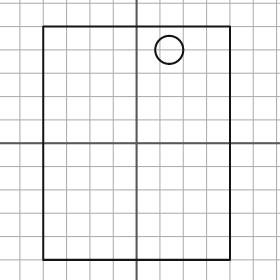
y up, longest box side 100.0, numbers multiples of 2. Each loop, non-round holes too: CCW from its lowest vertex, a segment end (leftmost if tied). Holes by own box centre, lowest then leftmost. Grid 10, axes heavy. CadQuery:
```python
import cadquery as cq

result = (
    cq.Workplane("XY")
    .moveTo(-40.0, -50.0)
    .lineTo(40.0, -50.0)
    .lineTo(40.0, 50.0)
    .lineTo(-40.0, 50.0)
    .close()
    .moveTo(14.0, 40.0)
    .circle(6.0)
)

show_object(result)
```